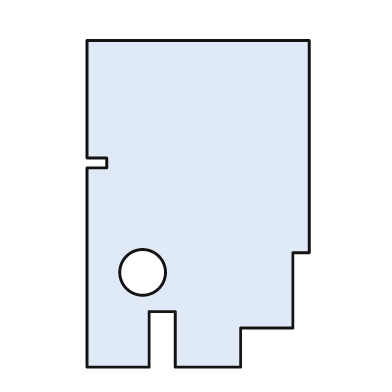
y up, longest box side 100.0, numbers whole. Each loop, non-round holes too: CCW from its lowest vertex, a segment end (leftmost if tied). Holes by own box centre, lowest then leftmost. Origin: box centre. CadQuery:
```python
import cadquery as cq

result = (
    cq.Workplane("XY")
    .moveTo(-34.0, -50.0)
    .lineTo(-15.0, -50.0)
    .lineTo(-15.0, -33.0)
    .lineTo(-7.0, -33.0)
    .lineTo(-7.0, -50.0)
    .lineTo(13.0, -50.0)
    .lineTo(13.0, -38.0)
    .lineTo(29.0, -38.0)
    .lineTo(29.0, -15.0)
    .lineTo(34.0, -15.0)
    .lineTo(34.0, 50.0)
    .lineTo(-34.0, 50.0)
    .lineTo(-34.0, 14.0)
    .lineTo(-28.0, 14.0)
    .lineTo(-28.0, 11.0)
    .lineTo(-34.0, 11.0)
    .close()
    .moveTo(-17.0, -21.0)
    .circle(7.0)
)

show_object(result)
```